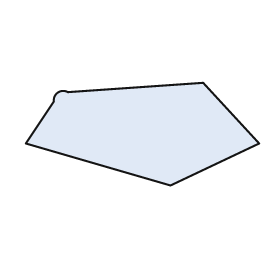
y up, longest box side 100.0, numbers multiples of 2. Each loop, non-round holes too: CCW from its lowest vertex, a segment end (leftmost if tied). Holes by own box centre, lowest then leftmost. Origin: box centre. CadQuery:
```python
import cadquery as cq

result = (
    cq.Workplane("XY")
    .moveTo(12.0, -22.0)
    .lineTo(50.0, -4.0)
    .lineTo(26.0, 22.0)
    .lineTo(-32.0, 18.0)
    .threePointArc((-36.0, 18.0), (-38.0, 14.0))
    .lineTo(-50.0, -4.0)
    .close()
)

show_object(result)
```